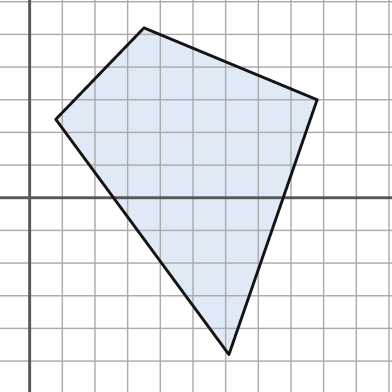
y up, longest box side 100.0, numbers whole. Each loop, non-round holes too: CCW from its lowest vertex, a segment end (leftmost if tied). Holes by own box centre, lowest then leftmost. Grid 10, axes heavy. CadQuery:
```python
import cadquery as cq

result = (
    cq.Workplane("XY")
    .moveTo(61.0, -48.0)
    .lineTo(88.0, 30.0)
    .lineTo(35.0, 52.0)
    .lineTo(8.0, 24.0)
    .close()
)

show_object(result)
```